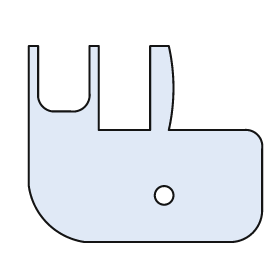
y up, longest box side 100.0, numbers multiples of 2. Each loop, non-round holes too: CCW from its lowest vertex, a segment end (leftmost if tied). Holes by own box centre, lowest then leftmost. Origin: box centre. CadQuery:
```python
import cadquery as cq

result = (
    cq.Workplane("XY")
    .moveTo(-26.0, -42.0)
    .lineTo(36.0, -42.0)
    .threePointArc((46.0, -38.0), (50.0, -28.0))
    .lineTo(50.0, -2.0)
    .threePointArc((48.0, 4.0), (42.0, 6.0))
    .lineTo(10.0, 6.0)
    .threePointArc((12.0, 24.0), (10.0, 42.0))
    .lineTo(2.0, 42.0)
    .lineTo(2.0, 6.0)
    .lineTo(-20.0, 6.0)
    .lineTo(-20.0, 42.0)
    .lineTo(-24.0, 42.0)
    .lineTo(-24.0, 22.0)
    .threePointArc((-26.0, 16.0), (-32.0, 14.0))
    .lineTo(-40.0, 14.0)
    .threePointArc((-44.0, 16.0), (-46.0, 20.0))
    .lineTo(-46.0, 42.0)
    .lineTo(-50.0, 42.0)
    .lineTo(-50.0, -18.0)
    .threePointArc((-42.0, -34.0), (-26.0, -42.0))
    .close()
    .moveTo(8.0, -22.0)
    .circle(4.0)
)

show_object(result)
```